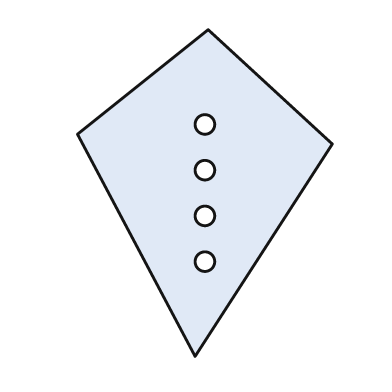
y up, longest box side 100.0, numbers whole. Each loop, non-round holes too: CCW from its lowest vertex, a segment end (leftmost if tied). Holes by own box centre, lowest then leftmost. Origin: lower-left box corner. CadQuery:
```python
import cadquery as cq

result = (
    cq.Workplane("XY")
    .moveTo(36.0, 0.0)
    .lineTo(78.0, 65.0)
    .lineTo(40.0, 100.0)
    .lineTo(0.0, 68.0)
    .close()
    .moveTo(39.0, 29.0)
    .circle(3.0)
    .moveTo(39.0, 43.0)
    .circle(3.0)
    .moveTo(39.0, 57.0)
    .circle(3.0)
    .moveTo(39.0, 71.0)
    .circle(3.0)
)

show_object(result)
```